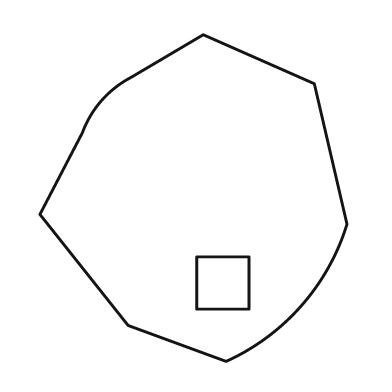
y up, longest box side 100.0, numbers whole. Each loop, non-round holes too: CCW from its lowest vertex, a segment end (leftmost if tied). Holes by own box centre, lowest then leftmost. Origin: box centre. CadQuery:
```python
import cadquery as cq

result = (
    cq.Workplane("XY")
    .moveTo(10.0, -50.0)
    .threePointArc((33.0, -33.0), (47.0, -8.0))
    .lineTo(37.0, 35.0)
    .lineTo(3.0, 50.0)
    .lineTo(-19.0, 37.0)
    .threePointArc((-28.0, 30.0), (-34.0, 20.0))
    .lineTo(-47.0, -5.0)
    .lineTo(-20.0, -39.0)
    .close()
    .moveTo(1.0, -34.0)
    .lineTo(17.0, -34.0)
    .lineTo(17.0, -18.0)
    .lineTo(1.0, -18.0)
    .close()
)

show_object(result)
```